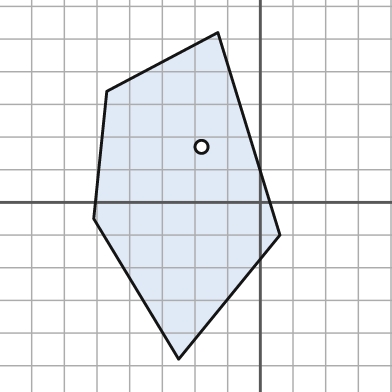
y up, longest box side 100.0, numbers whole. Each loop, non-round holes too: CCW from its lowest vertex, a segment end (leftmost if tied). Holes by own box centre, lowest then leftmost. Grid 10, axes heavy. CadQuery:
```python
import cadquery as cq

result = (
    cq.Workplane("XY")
    .moveTo(-25.0, -48.0)
    .lineTo(6.0, -10.0)
    .lineTo(-13.0, 52.0)
    .lineTo(-47.0, 34.0)
    .lineTo(-51.0, -5.0)
    .close()
    .moveTo(-18.0, 17.0)
    .circle(2.0)
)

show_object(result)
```